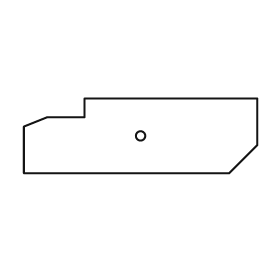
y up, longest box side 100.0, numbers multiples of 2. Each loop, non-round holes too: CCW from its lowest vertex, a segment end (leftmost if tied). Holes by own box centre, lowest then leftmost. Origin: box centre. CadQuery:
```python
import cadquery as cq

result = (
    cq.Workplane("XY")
    .moveTo(-50.0, -16.0)
    .lineTo(38.0, -16.0)
    .lineTo(50.0, -4.0)
    .lineTo(50.0, 16.0)
    .lineTo(-24.0, 16.0)
    .lineTo(-24.0, 8.0)
    .lineTo(-40.0, 8.0)
    .lineTo(-50.0, 4.0)
    .close()
    .moveTo(0.0, 0.0)
    .circle(2.0)
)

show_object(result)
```